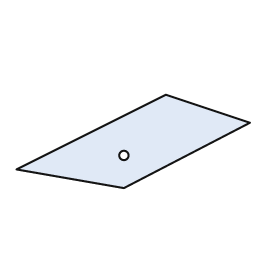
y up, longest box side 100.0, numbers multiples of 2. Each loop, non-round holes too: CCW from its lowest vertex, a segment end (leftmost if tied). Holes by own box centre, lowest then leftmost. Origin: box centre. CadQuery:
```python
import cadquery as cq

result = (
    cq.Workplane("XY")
    .moveTo(-4.0, -20.0)
    .lineTo(50.0, 8.0)
    .lineTo(14.0, 20.0)
    .lineTo(-50.0, -12.0)
    .close()
    .moveTo(-4.0, -6.0)
    .circle(2.0)
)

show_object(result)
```